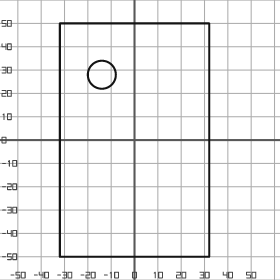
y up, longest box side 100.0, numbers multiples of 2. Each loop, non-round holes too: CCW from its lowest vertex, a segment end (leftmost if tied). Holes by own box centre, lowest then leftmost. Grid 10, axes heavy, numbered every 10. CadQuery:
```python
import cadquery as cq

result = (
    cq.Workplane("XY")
    .moveTo(-32.0, -50.0)
    .lineTo(32.0, -50.0)
    .lineTo(32.0, 50.0)
    .lineTo(-32.0, 50.0)
    .close()
    .moveTo(-14.0, 28.0)
    .circle(6.0)
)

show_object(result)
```